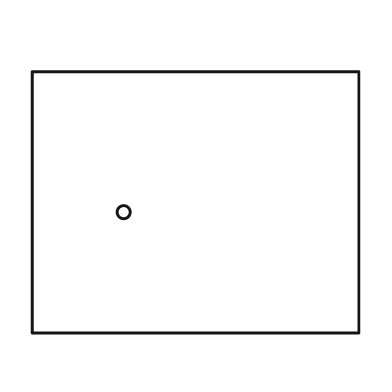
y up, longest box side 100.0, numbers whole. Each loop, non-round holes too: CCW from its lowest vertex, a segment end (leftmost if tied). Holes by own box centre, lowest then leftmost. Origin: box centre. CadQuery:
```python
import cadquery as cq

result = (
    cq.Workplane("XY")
    .moveTo(-50.0, -40.0)
    .lineTo(50.0, -40.0)
    .lineTo(50.0, 40.0)
    .lineTo(-50.0, 40.0)
    .close()
    .moveTo(-22.0, -3.0)
    .circle(2.0)
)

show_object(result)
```